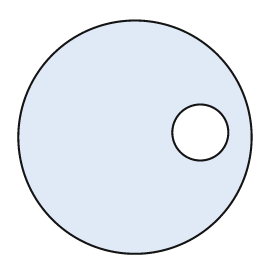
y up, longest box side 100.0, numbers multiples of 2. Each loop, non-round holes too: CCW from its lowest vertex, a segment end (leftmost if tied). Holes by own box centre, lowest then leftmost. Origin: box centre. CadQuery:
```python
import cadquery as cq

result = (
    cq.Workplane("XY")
    .moveTo(0.0, 0.0)
    .circle(50.0)
    .moveTo(28.0, 2.0)
    .circle(12.0)
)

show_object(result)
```